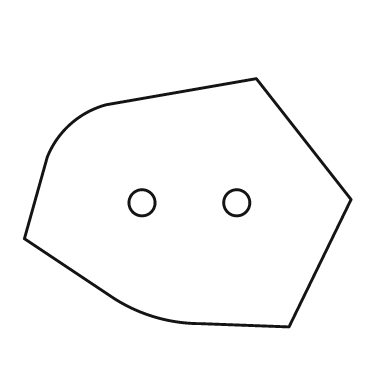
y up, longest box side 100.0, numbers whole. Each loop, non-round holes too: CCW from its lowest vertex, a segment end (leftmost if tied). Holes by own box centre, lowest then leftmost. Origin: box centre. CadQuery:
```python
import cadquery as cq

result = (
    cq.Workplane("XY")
    .moveTo(31.0, -38.0)
    .lineTo(50.0, 1.0)
    .lineTo(21.0, 38.0)
    .lineTo(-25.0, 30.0)
    .threePointArc((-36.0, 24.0), (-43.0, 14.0))
    .lineTo(-50.0, -11.0)
    .lineTo(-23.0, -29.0)
    .threePointArc((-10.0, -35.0), (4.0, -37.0))
    .close()
    .moveTo(-14.0, 0.0)
    .circle(4.0)
    .moveTo(15.0, 0.0)
    .circle(4.0)
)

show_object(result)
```